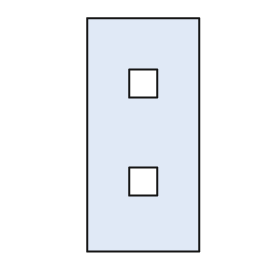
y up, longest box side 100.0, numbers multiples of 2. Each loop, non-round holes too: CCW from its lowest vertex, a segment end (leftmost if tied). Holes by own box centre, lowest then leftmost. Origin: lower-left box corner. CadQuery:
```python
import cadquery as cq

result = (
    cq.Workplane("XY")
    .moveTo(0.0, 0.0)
    .lineTo(48.0, 0.0)
    .lineTo(48.0, 100.0)
    .lineTo(0.0, 100.0)
    .close()
    .moveTo(18.0, 24.0)
    .lineTo(30.0, 24.0)
    .lineTo(30.0, 36.0)
    .lineTo(18.0, 36.0)
    .close()
    .moveTo(18.0, 66.0)
    .lineTo(30.0, 66.0)
    .lineTo(30.0, 78.0)
    .lineTo(18.0, 78.0)
    .close()
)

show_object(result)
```